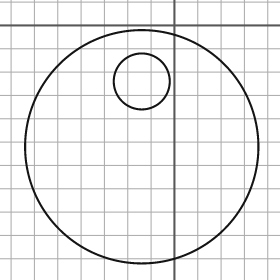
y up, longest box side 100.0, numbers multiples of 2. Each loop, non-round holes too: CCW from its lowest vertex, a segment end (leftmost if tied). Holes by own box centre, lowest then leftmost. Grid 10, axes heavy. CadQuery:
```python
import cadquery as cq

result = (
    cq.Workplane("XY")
    .moveTo(-14.0, -52.0)
    .circle(50.0)
    .moveTo(-14.0, -24.0)
    .circle(12.0)
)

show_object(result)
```